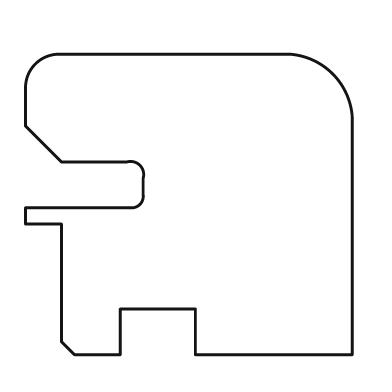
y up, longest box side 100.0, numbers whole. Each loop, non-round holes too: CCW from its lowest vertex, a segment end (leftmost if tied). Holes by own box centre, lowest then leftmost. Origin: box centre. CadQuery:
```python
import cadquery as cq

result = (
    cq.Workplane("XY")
    .moveTo(-35.0, -46.0)
    .lineTo(-21.0, -46.0)
    .lineTo(-21.0, -32.0)
    .lineTo(2.0, -32.0)
    .lineTo(2.0, -46.0)
    .lineTo(50.0, -46.0)
    .lineTo(50.0, 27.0)
    .threePointArc((44.0, 40.0), (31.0, 46.0))
    .lineTo(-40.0, 46.0)
    .threePointArc((-47.0, 43.0), (-50.0, 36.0))
    .lineTo(-50.0, 24.0)
    .lineTo(-39.0, 13.0)
    .lineTo(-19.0, 13.0)
    .threePointArc((-15.0, 12.0), (-14.0, 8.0))
    .lineTo(-14.0, 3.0)
    .threePointArc((-15.0, 0.0), (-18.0, -1.0))
    .lineTo(-50.0, -1.0)
    .lineTo(-50.0, -6.0)
    .lineTo(-39.0, -6.0)
    .lineTo(-39.0, -42.0)
    .close()
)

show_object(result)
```